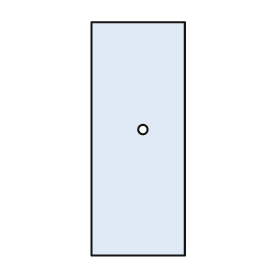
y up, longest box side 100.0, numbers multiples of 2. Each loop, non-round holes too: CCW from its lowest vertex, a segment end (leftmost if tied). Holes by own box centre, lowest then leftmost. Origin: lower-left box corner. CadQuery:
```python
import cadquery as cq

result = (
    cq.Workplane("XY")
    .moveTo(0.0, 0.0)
    .lineTo(40.0, 0.0)
    .lineTo(40.0, 100.0)
    .lineTo(0.0, 100.0)
    .close()
    .moveTo(22.0, 54.0)
    .circle(2.0)
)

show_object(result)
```